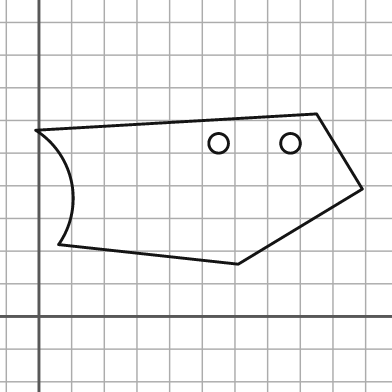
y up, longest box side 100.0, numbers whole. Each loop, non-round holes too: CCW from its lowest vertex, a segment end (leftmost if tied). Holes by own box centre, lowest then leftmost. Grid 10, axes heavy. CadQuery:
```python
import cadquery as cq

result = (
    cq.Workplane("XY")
    .moveTo(61.0, 16.0)
    .lineTo(99.0, 39.0)
    .lineTo(85.0, 62.0)
    .lineTo(-1.0, 57.0)
    .threePointArc((10.0, 41.0), (6.0, 22.0))
    .close()
    .moveTo(55.0, 53.0)
    .circle(3.0)
    .moveTo(77.0, 53.0)
    .circle(3.0)
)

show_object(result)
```